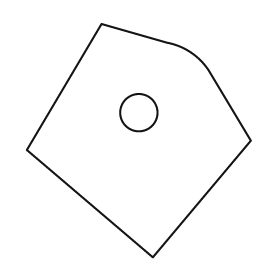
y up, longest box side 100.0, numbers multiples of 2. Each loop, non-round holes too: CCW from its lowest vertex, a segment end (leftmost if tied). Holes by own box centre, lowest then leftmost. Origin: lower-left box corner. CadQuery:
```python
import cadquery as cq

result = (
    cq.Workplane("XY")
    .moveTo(54.0, 0.0)
    .lineTo(96.0, 50.0)
    .lineTo(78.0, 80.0)
    .threePointArc((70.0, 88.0), (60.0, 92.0))
    .lineTo(32.0, 100.0)
    .lineTo(0.0, 46.0)
    .close()
    .moveTo(48.0, 62.0)
    .circle(8.0)
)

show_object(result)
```